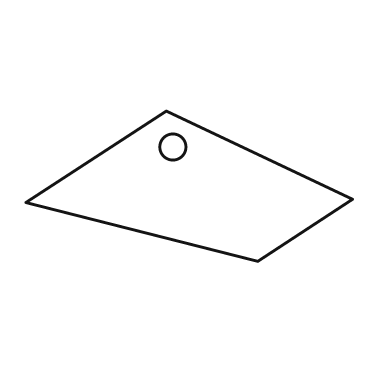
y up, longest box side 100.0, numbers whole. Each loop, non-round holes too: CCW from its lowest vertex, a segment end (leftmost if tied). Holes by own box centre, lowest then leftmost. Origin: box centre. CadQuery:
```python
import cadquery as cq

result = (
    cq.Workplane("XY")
    .moveTo(21.0, -23.0)
    .lineTo(50.0, -4.0)
    .lineTo(-7.0, 23.0)
    .lineTo(-50.0, -5.0)
    .close()
    .moveTo(-5.0, 12.0)
    .circle(4.0)
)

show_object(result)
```